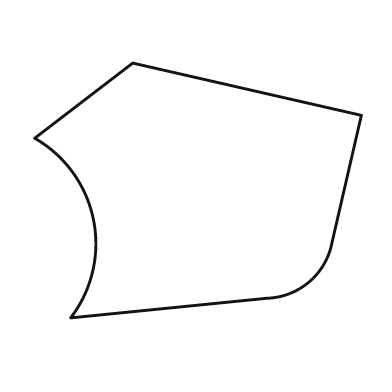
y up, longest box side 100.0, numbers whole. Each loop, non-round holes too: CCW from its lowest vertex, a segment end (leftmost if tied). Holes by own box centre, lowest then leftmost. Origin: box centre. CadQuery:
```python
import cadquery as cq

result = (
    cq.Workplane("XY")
    .moveTo(-39.0, -39.0)
    .lineTo(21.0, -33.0)
    .threePointArc((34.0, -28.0), (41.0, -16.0))
    .lineTo(50.0, 23.0)
    .lineTo(-20.0, 39.0)
    .lineTo(-50.0, 16.0)
    .threePointArc((-32.0, -9.0), (-39.0, -39.0))
    .close()
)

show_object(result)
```